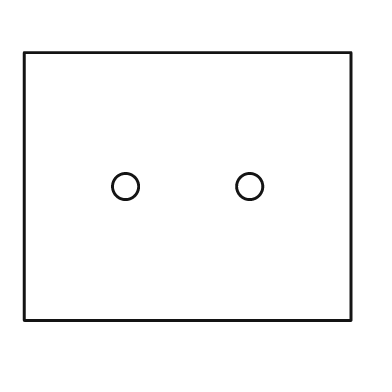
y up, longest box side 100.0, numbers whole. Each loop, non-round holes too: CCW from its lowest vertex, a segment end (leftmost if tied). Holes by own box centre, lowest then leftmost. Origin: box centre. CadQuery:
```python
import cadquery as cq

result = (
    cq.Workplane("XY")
    .moveTo(-50.0, -41.0)
    .lineTo(50.0, -41.0)
    .lineTo(50.0, 41.0)
    .lineTo(-50.0, 41.0)
    .close()
    .moveTo(-19.0, 0.0)
    .circle(4.0)
    .moveTo(19.0, 0.0)
    .circle(4.0)
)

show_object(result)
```